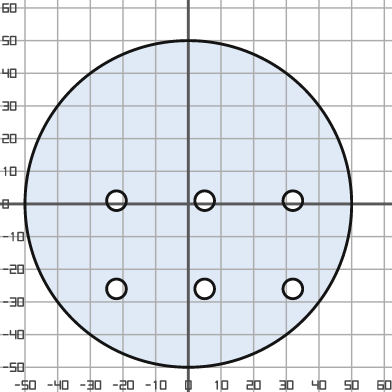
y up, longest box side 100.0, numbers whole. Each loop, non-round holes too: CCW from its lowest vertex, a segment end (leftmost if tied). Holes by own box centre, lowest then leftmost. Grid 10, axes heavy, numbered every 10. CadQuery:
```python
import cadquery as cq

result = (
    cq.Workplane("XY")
    .moveTo(0.0, 0.0)
    .circle(50.0)
    .moveTo(-22.0, -26.0)
    .circle(3.0)
    .moveTo(5.0, -26.0)
    .circle(3.0)
    .moveTo(32.0, -26.0)
    .circle(3.0)
    .moveTo(-22.0, 1.0)
    .circle(3.0)
    .moveTo(5.0, 1.0)
    .circle(3.0)
    .moveTo(32.0, 1.0)
    .circle(3.0)
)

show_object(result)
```